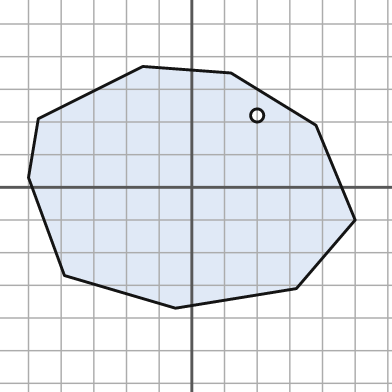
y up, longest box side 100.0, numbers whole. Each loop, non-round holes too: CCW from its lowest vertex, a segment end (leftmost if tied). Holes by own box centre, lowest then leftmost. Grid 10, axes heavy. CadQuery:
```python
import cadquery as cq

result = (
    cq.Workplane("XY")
    .moveTo(-5.0, -37.0)
    .lineTo(32.0, -31.0)
    .lineTo(50.0, -10.0)
    .lineTo(38.0, 19.0)
    .lineTo(12.0, 35.0)
    .lineTo(-15.0, 37.0)
    .lineTo(-47.0, 21.0)
    .lineTo(-50.0, 3.0)
    .lineTo(-39.0, -27.0)
    .close()
    .moveTo(20.0, 22.0)
    .circle(2.0)
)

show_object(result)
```